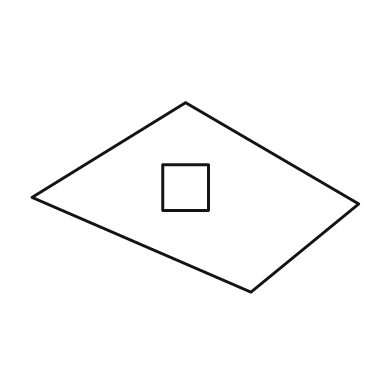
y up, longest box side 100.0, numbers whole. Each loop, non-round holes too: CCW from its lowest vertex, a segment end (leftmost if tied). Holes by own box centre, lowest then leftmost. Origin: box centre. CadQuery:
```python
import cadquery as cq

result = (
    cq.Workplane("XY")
    .moveTo(17.0, -29.0)
    .lineTo(50.0, -2.0)
    .lineTo(-3.0, 29.0)
    .lineTo(-50.0, 0.0)
    .close()
    .moveTo(-10.0, -4.0)
    .lineTo(4.0, -4.0)
    .lineTo(4.0, 10.0)
    .lineTo(-10.0, 10.0)
    .close()
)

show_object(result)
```